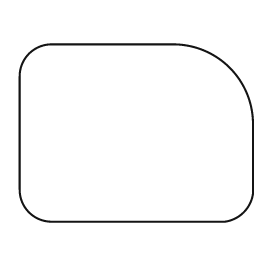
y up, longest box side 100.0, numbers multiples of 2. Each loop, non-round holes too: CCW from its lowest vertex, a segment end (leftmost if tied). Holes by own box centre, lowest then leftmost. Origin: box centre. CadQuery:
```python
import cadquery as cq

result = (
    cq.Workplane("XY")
    .moveTo(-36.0, -38.0)
    .lineTo(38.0, -38.0)
    .threePointArc((46.0, -34.0), (50.0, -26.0))
    .lineTo(50.0, 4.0)
    .threePointArc((40.0, 28.0), (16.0, 38.0))
    .lineTo(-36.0, 38.0)
    .threePointArc((-46.0, 34.0), (-50.0, 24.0))
    .lineTo(-50.0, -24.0)
    .threePointArc((-46.0, -34.0), (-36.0, -38.0))
    .close()
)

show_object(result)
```